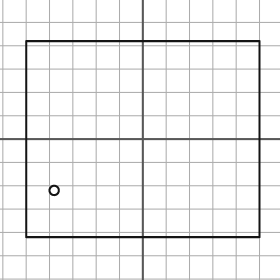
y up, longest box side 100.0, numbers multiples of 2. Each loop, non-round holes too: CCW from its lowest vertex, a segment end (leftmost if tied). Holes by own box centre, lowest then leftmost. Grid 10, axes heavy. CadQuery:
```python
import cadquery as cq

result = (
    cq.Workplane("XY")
    .moveTo(-50.0, -42.0)
    .lineTo(50.0, -42.0)
    .lineTo(50.0, 42.0)
    .lineTo(-50.0, 42.0)
    .close()
    .moveTo(-38.0, -22.0)
    .circle(2.0)
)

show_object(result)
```